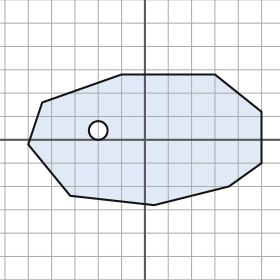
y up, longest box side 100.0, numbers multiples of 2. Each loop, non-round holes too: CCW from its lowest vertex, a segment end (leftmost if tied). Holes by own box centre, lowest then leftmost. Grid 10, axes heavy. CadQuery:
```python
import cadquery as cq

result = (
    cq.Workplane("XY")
    .moveTo(4.0, -28.0)
    .lineTo(36.0, -20.0)
    .lineTo(50.0, -10.0)
    .lineTo(50.0, 12.0)
    .lineTo(30.0, 28.0)
    .lineTo(-10.0, 28.0)
    .lineTo(-44.0, 16.0)
    .lineTo(-50.0, -2.0)
    .lineTo(-32.0, -24.0)
    .close()
    .moveTo(-20.0, 4.0)
    .circle(4.0)
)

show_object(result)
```